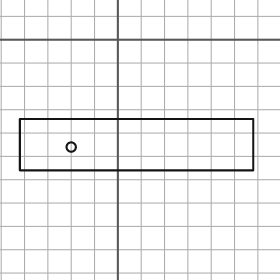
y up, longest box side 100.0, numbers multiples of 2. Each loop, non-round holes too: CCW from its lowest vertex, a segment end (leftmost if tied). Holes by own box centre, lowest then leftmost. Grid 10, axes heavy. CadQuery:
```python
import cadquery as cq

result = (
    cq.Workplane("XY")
    .moveTo(-42.0, -56.0)
    .lineTo(58.0, -56.0)
    .lineTo(58.0, -34.0)
    .lineTo(-42.0, -34.0)
    .close()
    .moveTo(-20.0, -46.0)
    .circle(2.0)
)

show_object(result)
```